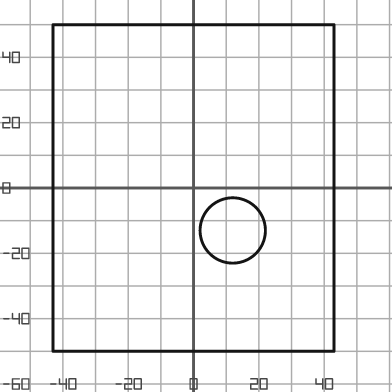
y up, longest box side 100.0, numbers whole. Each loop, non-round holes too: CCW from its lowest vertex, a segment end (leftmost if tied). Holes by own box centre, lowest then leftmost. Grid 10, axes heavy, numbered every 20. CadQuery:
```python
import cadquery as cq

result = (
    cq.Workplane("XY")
    .moveTo(-43.0, -50.0)
    .lineTo(43.0, -50.0)
    .lineTo(43.0, 50.0)
    .lineTo(-43.0, 50.0)
    .close()
    .moveTo(12.0, -13.0)
    .circle(10.0)
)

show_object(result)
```